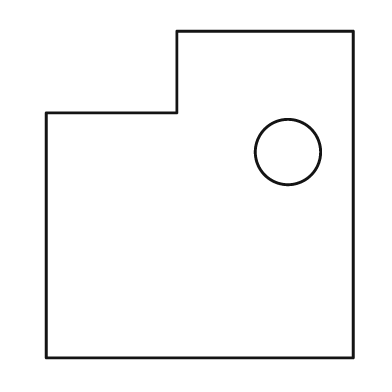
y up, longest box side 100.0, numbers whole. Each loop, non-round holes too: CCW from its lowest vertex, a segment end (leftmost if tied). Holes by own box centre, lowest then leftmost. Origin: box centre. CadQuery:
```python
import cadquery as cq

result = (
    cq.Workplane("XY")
    .moveTo(-47.0, -50.0)
    .lineTo(47.0, -50.0)
    .lineTo(47.0, 50.0)
    .lineTo(-7.0, 50.0)
    .lineTo(-7.0, 25.0)
    .lineTo(-47.0, 25.0)
    .close()
    .moveTo(27.0, 13.0)
    .circle(10.0)
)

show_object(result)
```